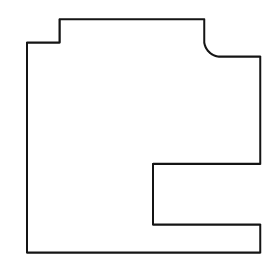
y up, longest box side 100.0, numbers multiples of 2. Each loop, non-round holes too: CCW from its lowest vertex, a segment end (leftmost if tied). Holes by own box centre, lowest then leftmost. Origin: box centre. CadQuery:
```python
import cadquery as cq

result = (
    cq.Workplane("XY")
    .moveTo(-50.0, -50.0)
    .lineTo(50.0, -50.0)
    .lineTo(50.0, -38.0)
    .lineTo(4.0, -38.0)
    .lineTo(4.0, -12.0)
    .lineTo(50.0, -12.0)
    .lineTo(50.0, 34.0)
    .lineTo(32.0, 34.0)
    .threePointArc((28.0, 36.0), (26.0, 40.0))
    .lineTo(26.0, 50.0)
    .lineTo(-36.0, 50.0)
    .lineTo(-36.0, 40.0)
    .lineTo(-50.0, 40.0)
    .close()
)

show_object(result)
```